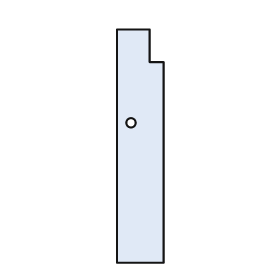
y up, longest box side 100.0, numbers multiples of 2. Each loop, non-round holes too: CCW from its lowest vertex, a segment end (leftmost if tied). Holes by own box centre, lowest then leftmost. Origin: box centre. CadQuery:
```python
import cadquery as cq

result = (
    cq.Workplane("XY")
    .moveTo(-10.0, -50.0)
    .lineTo(10.0, -50.0)
    .lineTo(10.0, 36.0)
    .lineTo(4.0, 36.0)
    .lineTo(4.0, 50.0)
    .lineTo(-10.0, 50.0)
    .close()
    .moveTo(-4.0, 10.0)
    .circle(2.0)
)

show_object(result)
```